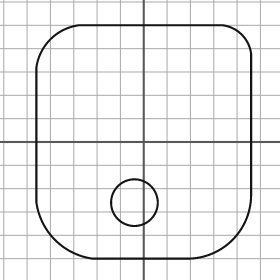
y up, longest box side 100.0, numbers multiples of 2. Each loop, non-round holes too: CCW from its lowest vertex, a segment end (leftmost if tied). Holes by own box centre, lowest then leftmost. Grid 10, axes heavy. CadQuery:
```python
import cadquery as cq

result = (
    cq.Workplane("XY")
    .moveTo(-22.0, -50.0)
    .lineTo(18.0, -50.0)
    .threePointArc((38.0, -42.0), (46.0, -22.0))
    .lineTo(46.0, 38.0)
    .threePointArc((42.0, 46.0), (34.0, 50.0))
    .lineTo(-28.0, 50.0)
    .threePointArc((-40.0, 44.0), (-46.0, 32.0))
    .lineTo(-46.0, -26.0)
    .threePointArc((-38.0, -42.0), (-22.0, -50.0))
    .close()
    .moveTo(-4.0, -26.0)
    .circle(10.0)
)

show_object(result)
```